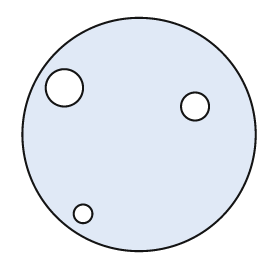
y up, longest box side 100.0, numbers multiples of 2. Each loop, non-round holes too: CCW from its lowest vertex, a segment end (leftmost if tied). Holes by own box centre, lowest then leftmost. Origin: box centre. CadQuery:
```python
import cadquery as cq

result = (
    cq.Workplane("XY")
    .moveTo(0.0, 0.0)
    .circle(50.0)
    .moveTo(-24.0, -34.0)
    .circle(4.0)
    .moveTo(24.0, 12.0)
    .circle(6.0)
    .moveTo(-32.0, 20.0)
    .circle(8.0)
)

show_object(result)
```